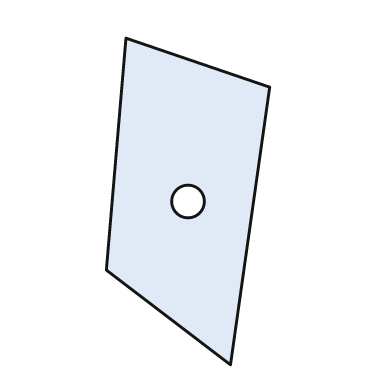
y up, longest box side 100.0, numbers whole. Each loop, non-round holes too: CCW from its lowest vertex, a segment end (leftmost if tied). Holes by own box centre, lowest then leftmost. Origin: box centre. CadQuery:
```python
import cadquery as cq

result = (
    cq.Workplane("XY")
    .moveTo(13.0, -50.0)
    .lineTo(25.0, 35.0)
    .lineTo(-19.0, 50.0)
    .lineTo(-25.0, -21.0)
    .close()
    .moveTo(0.0, 0.0)
    .circle(5.0)
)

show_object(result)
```